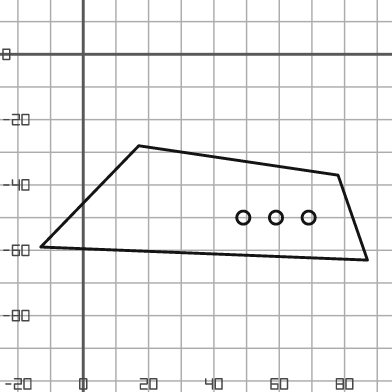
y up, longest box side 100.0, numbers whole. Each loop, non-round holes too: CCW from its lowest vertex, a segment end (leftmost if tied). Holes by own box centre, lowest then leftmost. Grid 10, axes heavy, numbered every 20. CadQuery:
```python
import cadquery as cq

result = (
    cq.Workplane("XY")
    .moveTo(87.0, -63.0)
    .lineTo(78.0, -37.0)
    .lineTo(17.0, -28.0)
    .lineTo(-13.0, -59.0)
    .close()
    .moveTo(49.0, -50.0)
    .circle(2.0)
    .moveTo(59.0, -50.0)
    .circle(2.0)
    .moveTo(69.0, -50.0)
    .circle(2.0)
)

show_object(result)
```